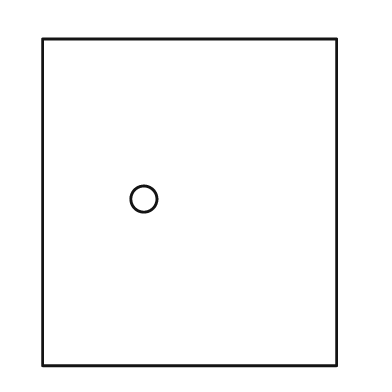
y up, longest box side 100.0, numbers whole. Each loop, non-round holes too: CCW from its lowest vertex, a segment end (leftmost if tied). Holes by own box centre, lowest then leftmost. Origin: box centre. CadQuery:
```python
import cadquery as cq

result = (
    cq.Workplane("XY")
    .moveTo(-45.0, -50.0)
    .lineTo(45.0, -50.0)
    .lineTo(45.0, 50.0)
    .lineTo(-45.0, 50.0)
    .close()
    .moveTo(-14.0, 1.0)
    .circle(4.0)
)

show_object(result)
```